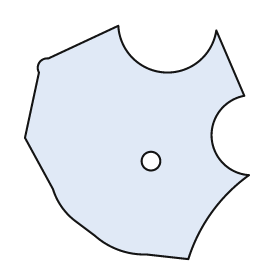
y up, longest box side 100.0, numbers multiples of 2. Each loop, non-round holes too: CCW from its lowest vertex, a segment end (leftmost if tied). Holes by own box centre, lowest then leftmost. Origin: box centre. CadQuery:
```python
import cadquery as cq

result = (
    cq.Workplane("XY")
    .moveTo(22.0, -50.0)
    .threePointArc((32.0, -30.0), (48.0, -14.0))
    .threePointArc((32.0, 2.0), (46.0, 20.0))
    .lineTo(34.0, 48.0)
    .threePointArc((12.0, 30.0), (-8.0, 50.0))
    .lineTo(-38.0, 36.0)
    .threePointArc((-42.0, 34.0), (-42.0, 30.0))
    .lineTo(-48.0, 2.0)
    .lineTo(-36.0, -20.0)
    .threePointArc((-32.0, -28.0), (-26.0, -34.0))
    .lineTo(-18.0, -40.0)
    .threePointArc((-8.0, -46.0), (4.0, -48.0))
    .close()
    .moveTo(6.0, -8.0)
    .circle(4.0)
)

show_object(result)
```